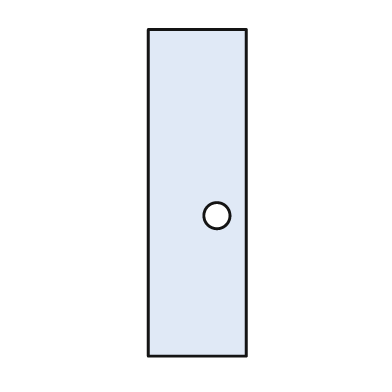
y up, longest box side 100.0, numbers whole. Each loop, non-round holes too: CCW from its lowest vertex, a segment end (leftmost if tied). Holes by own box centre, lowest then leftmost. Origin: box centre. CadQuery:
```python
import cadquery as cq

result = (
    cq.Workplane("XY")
    .moveTo(-15.0, -50.0)
    .lineTo(15.0, -50.0)
    .lineTo(15.0, 50.0)
    .lineTo(-15.0, 50.0)
    .close()
    .moveTo(6.0, -7.0)
    .circle(4.0)
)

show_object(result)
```